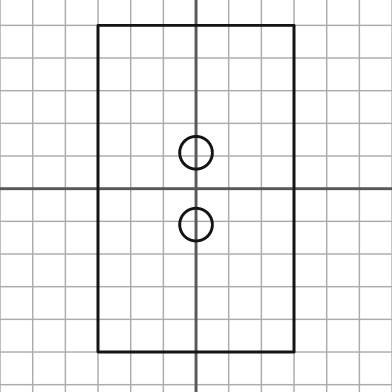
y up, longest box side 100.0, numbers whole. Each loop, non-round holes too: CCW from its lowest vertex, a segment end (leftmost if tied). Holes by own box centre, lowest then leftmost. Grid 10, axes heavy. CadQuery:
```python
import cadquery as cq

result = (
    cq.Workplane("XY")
    .moveTo(-30.0, -50.0)
    .lineTo(30.0, -50.0)
    .lineTo(30.0, 50.0)
    .lineTo(-30.0, 50.0)
    .close()
    .moveTo(0.0, -11.0)
    .circle(5.0)
    .moveTo(0.0, 11.0)
    .circle(5.0)
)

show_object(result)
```